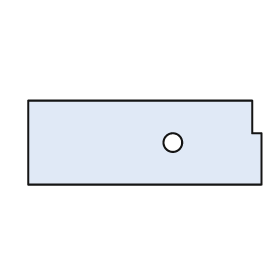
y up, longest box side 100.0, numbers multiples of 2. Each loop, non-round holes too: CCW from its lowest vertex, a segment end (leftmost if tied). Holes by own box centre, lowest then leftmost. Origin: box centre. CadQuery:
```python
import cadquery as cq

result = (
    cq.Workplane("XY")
    .moveTo(-50.0, -18.0)
    .lineTo(50.0, -18.0)
    .lineTo(50.0, 4.0)
    .lineTo(46.0, 4.0)
    .lineTo(46.0, 18.0)
    .lineTo(-50.0, 18.0)
    .close()
    .moveTo(12.0, 0.0)
    .circle(4.0)
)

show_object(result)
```